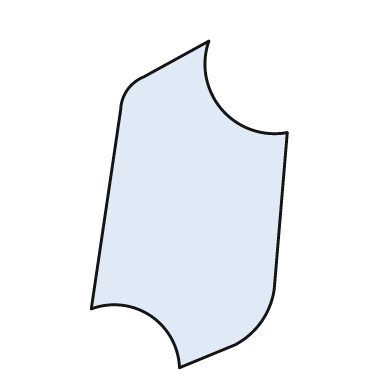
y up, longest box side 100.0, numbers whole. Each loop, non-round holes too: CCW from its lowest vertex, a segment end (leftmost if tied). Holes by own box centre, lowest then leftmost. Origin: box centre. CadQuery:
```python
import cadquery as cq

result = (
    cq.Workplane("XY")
    .moveTo(-3.0, -50.0)
    .lineTo(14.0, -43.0)
    .threePointArc((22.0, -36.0), (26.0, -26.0))
    .lineTo(30.0, 22.0)
    .threePointArc((10.0, 29.0), (6.0, 50.0))
    .lineTo(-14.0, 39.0)
    .threePointArc((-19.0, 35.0), (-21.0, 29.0))
    .lineTo(-30.0, -32.0)
    .threePointArc((-12.0, -34.0), (-3.0, -50.0))
    .close()
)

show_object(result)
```